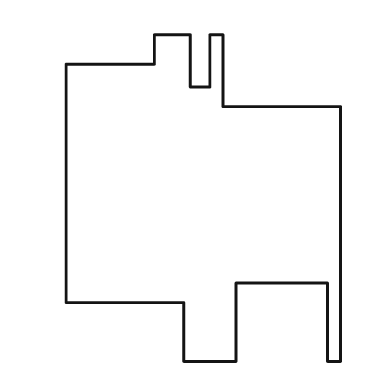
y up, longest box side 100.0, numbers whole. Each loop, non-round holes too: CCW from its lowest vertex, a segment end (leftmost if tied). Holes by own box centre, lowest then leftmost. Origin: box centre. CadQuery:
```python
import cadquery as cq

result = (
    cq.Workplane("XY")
    .moveTo(-6.0, -50.0)
    .lineTo(10.0, -50.0)
    .lineTo(10.0, -26.0)
    .lineTo(38.0, -26.0)
    .lineTo(38.0, -50.0)
    .lineTo(42.0, -50.0)
    .lineTo(42.0, 28.0)
    .lineTo(6.0, 28.0)
    .lineTo(6.0, 50.0)
    .lineTo(2.0, 50.0)
    .lineTo(2.0, 34.0)
    .lineTo(-4.0, 34.0)
    .lineTo(-4.0, 50.0)
    .lineTo(-15.0, 50.0)
    .lineTo(-15.0, 41.0)
    .lineTo(-42.0, 41.0)
    .lineTo(-42.0, -32.0)
    .lineTo(-6.0, -32.0)
    .close()
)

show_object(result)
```